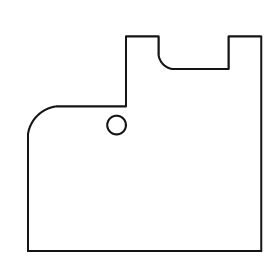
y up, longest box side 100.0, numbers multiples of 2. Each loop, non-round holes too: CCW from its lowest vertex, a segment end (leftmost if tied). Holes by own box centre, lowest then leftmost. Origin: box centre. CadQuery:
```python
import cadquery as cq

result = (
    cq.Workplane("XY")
    .moveTo(-50.0, -46.0)
    .lineTo(50.0, -46.0)
    .lineTo(50.0, 46.0)
    .lineTo(36.0, 46.0)
    .lineTo(36.0, 32.0)
    .lineTo(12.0, 32.0)
    .threePointArc((8.0, 34.0), (6.0, 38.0))
    .lineTo(6.0, 46.0)
    .lineTo(-8.0, 46.0)
    .lineTo(-8.0, 16.0)
    .lineTo(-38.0, 16.0)
    .threePointArc((-46.0, 12.0), (-50.0, 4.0))
    .close()
    .moveTo(-12.0, 8.0)
    .circle(4.0)
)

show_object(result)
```